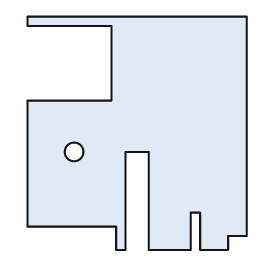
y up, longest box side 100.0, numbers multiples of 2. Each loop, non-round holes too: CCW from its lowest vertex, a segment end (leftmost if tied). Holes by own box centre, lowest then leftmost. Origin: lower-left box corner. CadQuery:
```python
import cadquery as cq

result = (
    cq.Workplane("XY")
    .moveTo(38.0, 0.0)
    .lineTo(42.0, 0.0)
    .lineTo(42.0, 42.0)
    .lineTo(52.0, 42.0)
    .lineTo(52.0, 0.0)
    .lineTo(70.0, 0.0)
    .lineTo(70.0, 16.0)
    .lineTo(74.0, 16.0)
    .lineTo(74.0, 0.0)
    .lineTo(86.0, 0.0)
    .lineTo(86.0, 6.0)
    .lineTo(94.0, 6.0)
    .lineTo(94.0, 100.0)
    .lineTo(0.0, 100.0)
    .lineTo(0.0, 96.0)
    .lineTo(36.0, 96.0)
    .lineTo(36.0, 64.0)
    .lineTo(0.0, 64.0)
    .lineTo(0.0, 10.0)
    .lineTo(38.0, 10.0)
    .close()
    .moveTo(20.0, 42.0)
    .circle(4.0)
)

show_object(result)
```